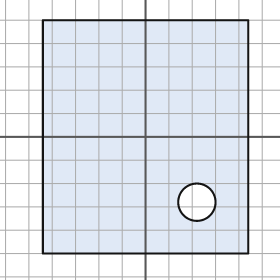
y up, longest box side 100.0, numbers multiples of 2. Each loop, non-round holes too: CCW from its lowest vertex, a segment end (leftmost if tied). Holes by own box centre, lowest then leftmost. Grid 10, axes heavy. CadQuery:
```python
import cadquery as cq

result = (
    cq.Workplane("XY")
    .moveTo(-44.0, -50.0)
    .lineTo(44.0, -50.0)
    .lineTo(44.0, 50.0)
    .lineTo(-44.0, 50.0)
    .close()
    .moveTo(22.0, -28.0)
    .circle(8.0)
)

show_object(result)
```